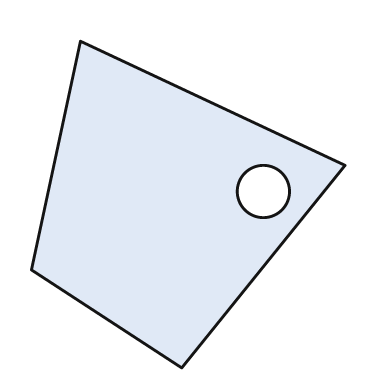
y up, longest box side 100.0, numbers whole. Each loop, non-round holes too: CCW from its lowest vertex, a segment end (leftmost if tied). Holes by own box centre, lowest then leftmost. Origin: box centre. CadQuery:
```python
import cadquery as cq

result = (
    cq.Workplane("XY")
    .moveTo(-2.0, -50.0)
    .lineTo(48.0, 12.0)
    .lineTo(-33.0, 50.0)
    .lineTo(-48.0, -20.0)
    .close()
    .moveTo(23.0, 4.0)
    .circle(8.0)
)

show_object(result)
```